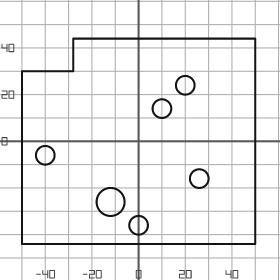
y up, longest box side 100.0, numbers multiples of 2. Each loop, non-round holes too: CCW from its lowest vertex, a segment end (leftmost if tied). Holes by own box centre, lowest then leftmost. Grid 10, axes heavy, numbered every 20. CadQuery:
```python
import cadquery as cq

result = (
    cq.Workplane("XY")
    .moveTo(-50.0, -44.0)
    .lineTo(50.0, -44.0)
    .lineTo(50.0, 44.0)
    .lineTo(-28.0, 44.0)
    .lineTo(-28.0, 30.0)
    .lineTo(-50.0, 30.0)
    .close()
    .moveTo(0.0, -36.0)
    .circle(4.0)
    .moveTo(-12.0, -26.0)
    .circle(6.0)
    .moveTo(26.0, -16.0)
    .circle(4.0)
    .moveTo(-40.0, -6.0)
    .circle(4.0)
    .moveTo(10.0, 14.0)
    .circle(4.0)
    .moveTo(20.0, 24.0)
    .circle(4.0)
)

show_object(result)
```